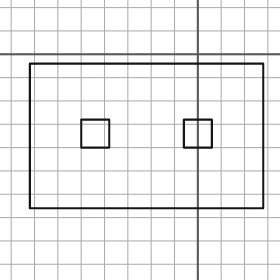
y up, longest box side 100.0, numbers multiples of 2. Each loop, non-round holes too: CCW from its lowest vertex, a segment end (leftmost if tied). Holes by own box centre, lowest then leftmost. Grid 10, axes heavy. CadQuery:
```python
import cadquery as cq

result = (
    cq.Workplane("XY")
    .moveTo(-72.0, -66.0)
    .lineTo(28.0, -66.0)
    .lineTo(28.0, -4.0)
    .lineTo(-72.0, -4.0)
    .close()
    .moveTo(-50.0, -40.0)
    .lineTo(-38.0, -40.0)
    .lineTo(-38.0, -28.0)
    .lineTo(-50.0, -28.0)
    .close()
    .moveTo(-6.0, -40.0)
    .lineTo(6.0, -40.0)
    .lineTo(6.0, -28.0)
    .lineTo(-6.0, -28.0)
    .close()
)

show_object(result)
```